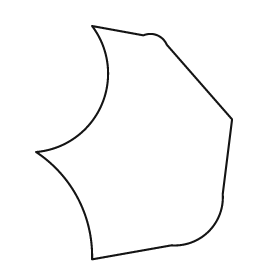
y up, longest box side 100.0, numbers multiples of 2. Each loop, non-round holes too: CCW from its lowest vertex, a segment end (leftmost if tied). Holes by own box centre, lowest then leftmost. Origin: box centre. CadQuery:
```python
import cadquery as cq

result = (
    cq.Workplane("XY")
    .moveTo(-18.0, -50.0)
    .lineTo(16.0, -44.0)
    .threePointArc((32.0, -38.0), (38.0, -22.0))
    .lineTo(42.0, 10.0)
    .lineTo(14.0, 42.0)
    .threePointArc((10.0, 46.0), (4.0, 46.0))
    .lineTo(-18.0, 50.0)
    .threePointArc((-14.0, 16.0), (-42.0, -4.0))
    .threePointArc((-24.0, -24.0), (-18.0, -50.0))
    .close()
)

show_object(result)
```